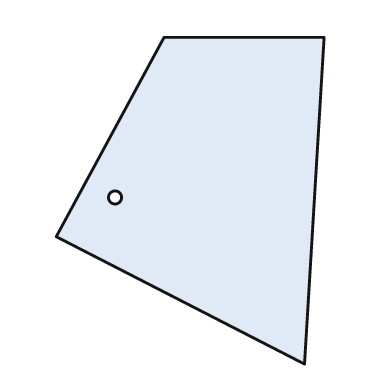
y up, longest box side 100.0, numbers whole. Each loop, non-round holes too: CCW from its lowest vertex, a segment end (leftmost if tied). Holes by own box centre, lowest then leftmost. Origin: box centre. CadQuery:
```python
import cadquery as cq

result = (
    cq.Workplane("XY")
    .moveTo(35.0, -50.0)
    .lineTo(41.0, 50.0)
    .lineTo(-8.0, 50.0)
    .lineTo(-41.0, -11.0)
    .close()
    .moveTo(-23.0, 1.0)
    .circle(2.0)
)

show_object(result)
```